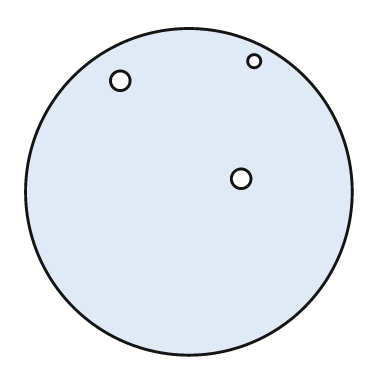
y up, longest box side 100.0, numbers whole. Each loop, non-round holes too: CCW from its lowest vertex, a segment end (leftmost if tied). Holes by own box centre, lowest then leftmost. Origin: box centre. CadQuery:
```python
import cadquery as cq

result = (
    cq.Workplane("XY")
    .moveTo(0.0, 0.0)
    .circle(50.0)
    .moveTo(16.0, 4.0)
    .circle(3.0)
    .moveTo(-21.0, 34.0)
    .circle(3.0)
    .moveTo(20.0, 40.0)
    .circle(2.0)
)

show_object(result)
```